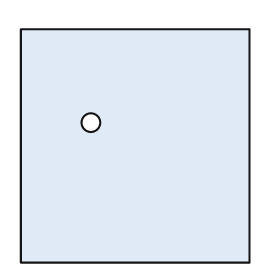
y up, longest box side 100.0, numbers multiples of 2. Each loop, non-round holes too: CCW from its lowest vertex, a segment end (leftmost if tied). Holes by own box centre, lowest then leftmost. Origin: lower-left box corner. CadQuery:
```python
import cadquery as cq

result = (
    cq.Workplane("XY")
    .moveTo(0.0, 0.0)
    .lineTo(98.0, 0.0)
    .lineTo(98.0, 100.0)
    .lineTo(0.0, 100.0)
    .close()
    .moveTo(30.0, 60.0)
    .circle(4.0)
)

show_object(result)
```